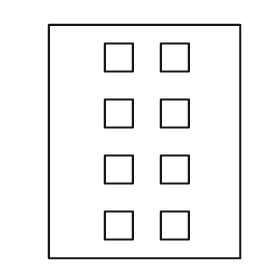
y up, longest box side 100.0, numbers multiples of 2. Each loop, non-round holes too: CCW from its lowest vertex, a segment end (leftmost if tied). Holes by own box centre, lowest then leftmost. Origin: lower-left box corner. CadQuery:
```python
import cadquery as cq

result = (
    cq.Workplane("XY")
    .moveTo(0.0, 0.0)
    .lineTo(82.0, 0.0)
    .lineTo(82.0, 100.0)
    .lineTo(0.0, 100.0)
    .close()
    .moveTo(24.0, 8.0)
    .lineTo(36.0, 8.0)
    .lineTo(36.0, 20.0)
    .lineTo(24.0, 20.0)
    .close()
    .moveTo(48.0, 8.0)
    .lineTo(60.0, 8.0)
    .lineTo(60.0, 20.0)
    .lineTo(48.0, 20.0)
    .close()
    .moveTo(24.0, 32.0)
    .lineTo(36.0, 32.0)
    .lineTo(36.0, 44.0)
    .lineTo(24.0, 44.0)
    .close()
    .moveTo(48.0, 32.0)
    .lineTo(60.0, 32.0)
    .lineTo(60.0, 44.0)
    .lineTo(48.0, 44.0)
    .close()
    .moveTo(24.0, 56.0)
    .lineTo(36.0, 56.0)
    .lineTo(36.0, 68.0)
    .lineTo(24.0, 68.0)
    .close()
    .moveTo(48.0, 56.0)
    .lineTo(60.0, 56.0)
    .lineTo(60.0, 68.0)
    .lineTo(48.0, 68.0)
    .close()
    .moveTo(24.0, 80.0)
    .lineTo(36.0, 80.0)
    .lineTo(36.0, 92.0)
    .lineTo(24.0, 92.0)
    .close()
    .moveTo(48.0, 80.0)
    .lineTo(60.0, 80.0)
    .lineTo(60.0, 92.0)
    .lineTo(48.0, 92.0)
    .close()
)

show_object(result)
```